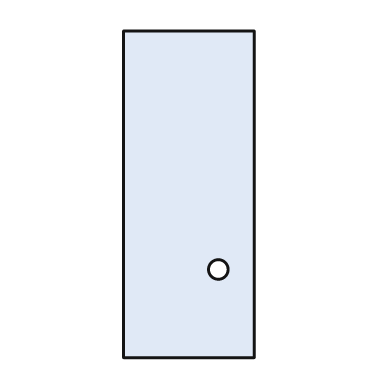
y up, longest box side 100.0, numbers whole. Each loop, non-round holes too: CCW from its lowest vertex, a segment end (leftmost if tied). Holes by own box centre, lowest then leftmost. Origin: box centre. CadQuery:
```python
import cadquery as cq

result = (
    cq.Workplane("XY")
    .moveTo(-20.0, -50.0)
    .lineTo(20.0, -50.0)
    .lineTo(20.0, 50.0)
    .lineTo(-20.0, 50.0)
    .close()
    .moveTo(9.0, -23.0)
    .circle(3.0)
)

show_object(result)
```